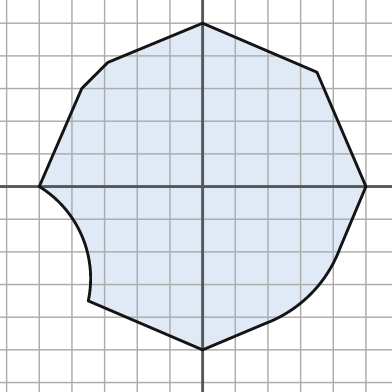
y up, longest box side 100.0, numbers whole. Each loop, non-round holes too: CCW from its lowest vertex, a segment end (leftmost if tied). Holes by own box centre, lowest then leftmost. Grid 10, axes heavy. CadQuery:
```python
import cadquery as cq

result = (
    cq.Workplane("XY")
    .moveTo(0.0, -50.0)
    .lineTo(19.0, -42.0)
    .threePointArc((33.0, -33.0), (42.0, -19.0))
    .lineTo(50.0, 0.0)
    .lineTo(35.0, 35.0)
    .lineTo(0.0, 50.0)
    .lineTo(-29.0, 38.0)
    .lineTo(-37.0, 30.0)
    .lineTo(-50.0, 0.0)
    .threePointArc((-37.0, -15.0), (-35.0, -35.0))
    .close()
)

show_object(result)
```